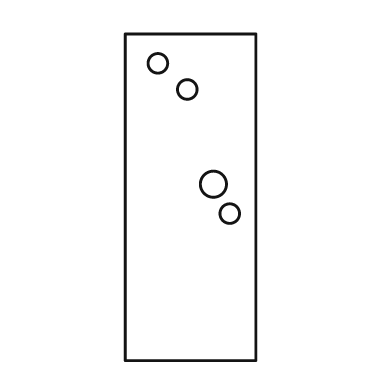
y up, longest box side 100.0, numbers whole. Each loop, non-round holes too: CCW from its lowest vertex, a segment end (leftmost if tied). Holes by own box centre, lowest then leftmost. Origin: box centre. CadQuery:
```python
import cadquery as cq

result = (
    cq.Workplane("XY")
    .moveTo(-20.0, -50.0)
    .lineTo(20.0, -50.0)
    .lineTo(20.0, 50.0)
    .lineTo(-20.0, 50.0)
    .close()
    .moveTo(12.0, -5.0)
    .circle(3.0)
    .moveTo(7.0, 4.0)
    .circle(4.0)
    .moveTo(-1.0, 33.0)
    .circle(3.0)
    .moveTo(-10.0, 41.0)
    .circle(3.0)
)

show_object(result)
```